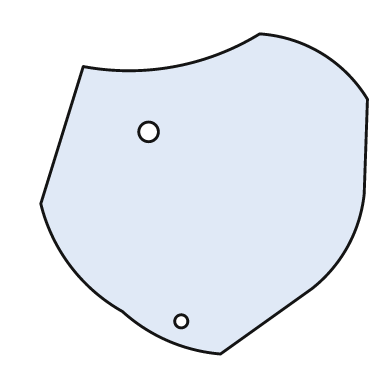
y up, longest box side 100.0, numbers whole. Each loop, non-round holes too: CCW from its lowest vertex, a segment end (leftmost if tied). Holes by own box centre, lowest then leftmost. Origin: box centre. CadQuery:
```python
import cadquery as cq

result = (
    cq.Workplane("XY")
    .moveTo(5.0, -49.0)
    .lineTo(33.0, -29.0)
    .threePointArc((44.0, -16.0), (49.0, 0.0))
    .lineTo(50.0, 29.0)
    .threePointArc((36.0, 43.0), (17.0, 49.0))
    .threePointArc((-9.0, 39.0), (-37.0, 39.0))
    .lineTo(-50.0, -3.0)
    .threePointArc((-41.0, -22.0), (-25.0, -36.0))
    .threePointArc((-11.0, -45.0), (5.0, -49.0))
    .close()
    .moveTo(-7.0, -39.0)
    .circle(2.0)
    .moveTo(-17.0, 19.0)
    .circle(3.0)
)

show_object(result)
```